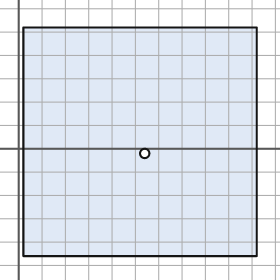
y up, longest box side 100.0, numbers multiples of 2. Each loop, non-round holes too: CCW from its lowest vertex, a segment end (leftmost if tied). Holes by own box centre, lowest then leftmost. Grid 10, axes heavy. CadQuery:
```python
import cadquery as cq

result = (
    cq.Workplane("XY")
    .moveTo(2.0, -46.0)
    .lineTo(102.0, -46.0)
    .lineTo(102.0, 52.0)
    .lineTo(2.0, 52.0)
    .close()
    .moveTo(54.0, -2.0)
    .circle(2.0)
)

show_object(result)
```